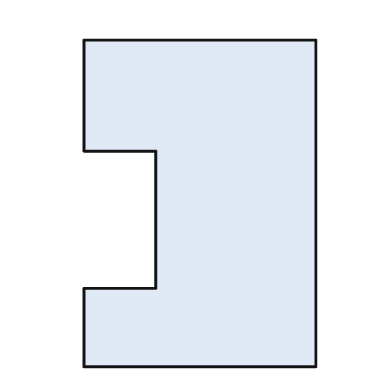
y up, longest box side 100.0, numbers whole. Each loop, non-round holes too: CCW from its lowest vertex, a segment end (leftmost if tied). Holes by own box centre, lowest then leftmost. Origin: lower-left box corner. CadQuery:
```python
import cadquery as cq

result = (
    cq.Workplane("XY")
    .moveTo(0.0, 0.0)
    .lineTo(71.0, 0.0)
    .lineTo(71.0, 100.0)
    .lineTo(0.0, 100.0)
    .lineTo(0.0, 66.0)
    .lineTo(22.0, 66.0)
    .lineTo(22.0, 24.0)
    .lineTo(0.0, 24.0)
    .close()
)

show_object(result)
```